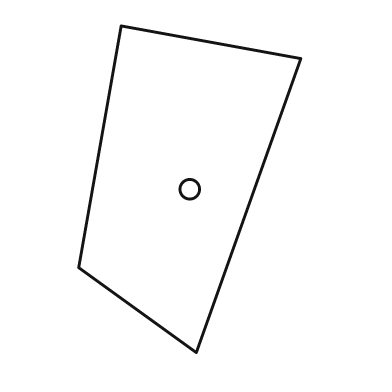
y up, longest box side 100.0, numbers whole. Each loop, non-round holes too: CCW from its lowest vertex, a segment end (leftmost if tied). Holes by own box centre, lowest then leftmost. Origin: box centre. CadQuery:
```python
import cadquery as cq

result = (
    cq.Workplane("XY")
    .moveTo(2.0, -50.0)
    .lineTo(34.0, 40.0)
    .lineTo(-21.0, 50.0)
    .lineTo(-34.0, -24.0)
    .close()
    .moveTo(0.0, 0.0)
    .circle(3.0)
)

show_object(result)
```